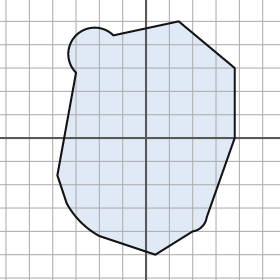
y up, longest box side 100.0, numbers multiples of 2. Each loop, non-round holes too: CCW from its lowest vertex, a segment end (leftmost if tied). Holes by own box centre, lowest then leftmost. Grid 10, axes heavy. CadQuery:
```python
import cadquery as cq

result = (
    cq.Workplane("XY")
    .moveTo(4.0, -50.0)
    .lineTo(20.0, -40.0)
    .threePointArc((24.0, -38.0), (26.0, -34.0))
    .lineTo(38.0, 0.0)
    .lineTo(38.0, 30.0)
    .lineTo(14.0, 50.0)
    .lineTo(-14.0, 44.0)
    .threePointArc((-30.0, 44.0), (-30.0, 28.0))
    .lineTo(-38.0, -16.0)
    .lineTo(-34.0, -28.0)
    .threePointArc((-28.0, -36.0), (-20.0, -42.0))
    .close()
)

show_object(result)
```